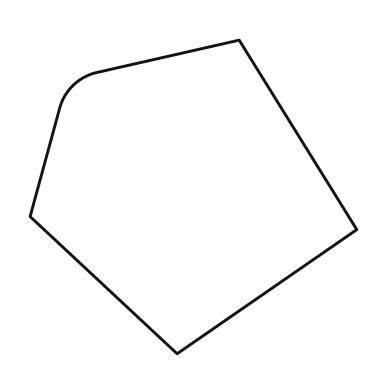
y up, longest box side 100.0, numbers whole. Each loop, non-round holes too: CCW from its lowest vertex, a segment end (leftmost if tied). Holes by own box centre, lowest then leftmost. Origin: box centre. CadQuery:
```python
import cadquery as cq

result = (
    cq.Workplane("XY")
    .moveTo(-5.0, -48.0)
    .lineTo(50.0, -10.0)
    .lineTo(14.0, 48.0)
    .lineTo(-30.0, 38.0)
    .threePointArc((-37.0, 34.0), (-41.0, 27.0))
    .lineTo(-50.0, -6.0)
    .close()
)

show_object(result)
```